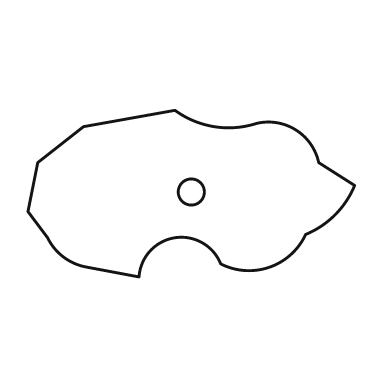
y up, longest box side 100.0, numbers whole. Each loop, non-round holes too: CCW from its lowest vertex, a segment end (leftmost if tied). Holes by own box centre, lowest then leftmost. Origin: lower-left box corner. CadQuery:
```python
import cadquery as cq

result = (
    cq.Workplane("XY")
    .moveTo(34.0, 0.0)
    .threePointArc((45.0, 12.0), (59.0, 4.0))
    .threePointArc((74.0, 3.0), (85.0, 13.0))
    .threePointArc((94.0, 19.0), (100.0, 28.0))
    .lineTo(89.0, 35.0)
    .threePointArc((82.0, 45.0), (70.0, 47.0))
    .threePointArc((57.0, 46.0), (45.0, 51.0))
    .lineTo(17.0, 46.0)
    .lineTo(3.0, 35.0)
    .lineTo(0.0, 20.0)
    .lineTo(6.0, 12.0)
    .threePointArc((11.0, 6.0), (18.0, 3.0))
    .close()
    .moveTo(50.0, 26.0)
    .circle(4.0)
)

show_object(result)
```